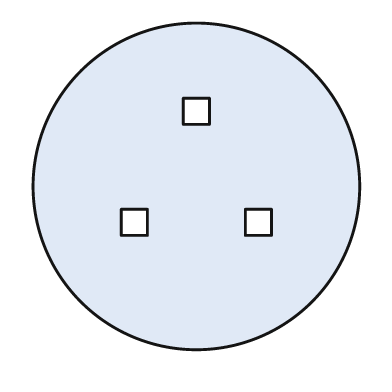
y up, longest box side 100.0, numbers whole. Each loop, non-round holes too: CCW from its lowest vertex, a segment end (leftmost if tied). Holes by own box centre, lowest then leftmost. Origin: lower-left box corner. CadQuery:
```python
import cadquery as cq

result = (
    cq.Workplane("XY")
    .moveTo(50.0, 50.0)
    .circle(50.0)
    .moveTo(27.0, 35.0)
    .lineTo(35.0, 35.0)
    .lineTo(35.0, 43.0)
    .lineTo(27.0, 43.0)
    .close()
    .moveTo(65.0, 35.0)
    .lineTo(73.0, 35.0)
    .lineTo(73.0, 43.0)
    .lineTo(65.0, 43.0)
    .close()
    .moveTo(46.0, 69.0)
    .lineTo(54.0, 69.0)
    .lineTo(54.0, 77.0)
    .lineTo(46.0, 77.0)
    .close()
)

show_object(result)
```